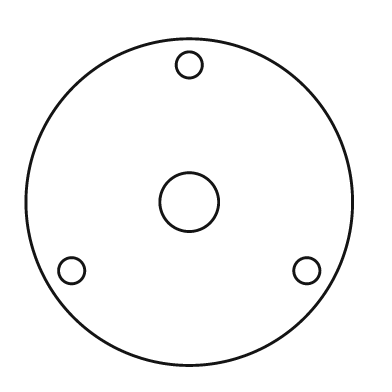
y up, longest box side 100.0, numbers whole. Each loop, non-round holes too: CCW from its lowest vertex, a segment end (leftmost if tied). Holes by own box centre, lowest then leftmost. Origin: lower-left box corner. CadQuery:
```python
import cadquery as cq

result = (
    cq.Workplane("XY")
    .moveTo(50.0, 50.0)
    .circle(50.0)
    .moveTo(14.0, 29.0)
    .circle(4.0)
    .moveTo(86.0, 29.0)
    .circle(4.0)
    .moveTo(50.0, 50.0)
    .circle(9.0)
    .moveTo(50.0, 92.0)
    .circle(4.0)
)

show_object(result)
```